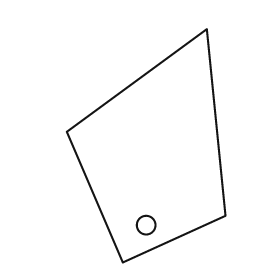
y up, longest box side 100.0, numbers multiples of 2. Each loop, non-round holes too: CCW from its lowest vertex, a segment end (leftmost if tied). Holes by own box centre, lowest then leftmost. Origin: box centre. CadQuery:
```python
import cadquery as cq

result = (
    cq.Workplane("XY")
    .moveTo(-10.0, -50.0)
    .lineTo(34.0, -30.0)
    .lineTo(26.0, 50.0)
    .lineTo(-34.0, 6.0)
    .close()
    .moveTo(0.0, -34.0)
    .circle(4.0)
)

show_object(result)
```